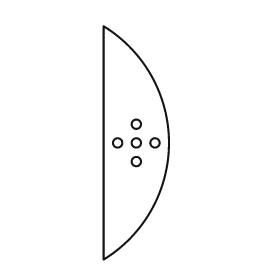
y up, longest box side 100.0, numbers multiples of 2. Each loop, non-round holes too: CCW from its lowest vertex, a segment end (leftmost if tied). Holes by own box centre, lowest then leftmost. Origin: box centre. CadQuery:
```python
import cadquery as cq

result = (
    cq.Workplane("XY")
    .moveTo(-14.0, -50.0)
    .threePointArc((14.0, 0.0), (-14.0, 50.0))
    .close()
    .moveTo(0.0, -8.0)
    .circle(2.0)
    .moveTo(-8.0, 0.0)
    .circle(2.0)
    .moveTo(0.0, 0.0)
    .circle(2.0)
    .moveTo(8.0, 0.0)
    .circle(2.0)
    .moveTo(0.0, 8.0)
    .circle(2.0)
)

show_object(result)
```